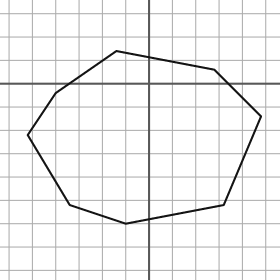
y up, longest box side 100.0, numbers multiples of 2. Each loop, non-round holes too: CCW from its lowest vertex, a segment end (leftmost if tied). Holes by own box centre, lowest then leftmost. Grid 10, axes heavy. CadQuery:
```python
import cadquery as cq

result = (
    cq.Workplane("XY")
    .moveTo(-10.0, -60.0)
    .lineTo(32.0, -52.0)
    .lineTo(48.0, -14.0)
    .lineTo(28.0, 6.0)
    .lineTo(-14.0, 14.0)
    .lineTo(-40.0, -4.0)
    .lineTo(-52.0, -22.0)
    .lineTo(-34.0, -52.0)
    .close()
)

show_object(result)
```